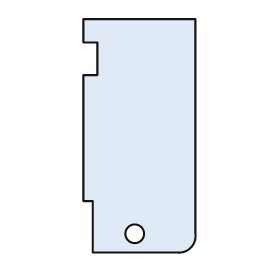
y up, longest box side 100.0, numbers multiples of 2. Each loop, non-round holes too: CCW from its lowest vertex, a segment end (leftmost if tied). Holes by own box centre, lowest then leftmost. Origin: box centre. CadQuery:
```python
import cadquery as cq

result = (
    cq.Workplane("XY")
    .moveTo(-20.0, -50.0)
    .lineTo(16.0, -50.0)
    .threePointArc((22.0, -48.0), (24.0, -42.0))
    .lineTo(24.0, 50.0)
    .lineTo(-24.0, 50.0)
    .lineTo(-24.0, 40.0)
    .lineTo(-18.0, 40.0)
    .lineTo(-18.0, 26.0)
    .lineTo(-24.0, 26.0)
    .lineTo(-24.0, -28.0)
    .lineTo(-20.0, -28.0)
    .close()
    .moveTo(-2.0, -42.0)
    .circle(4.0)
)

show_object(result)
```